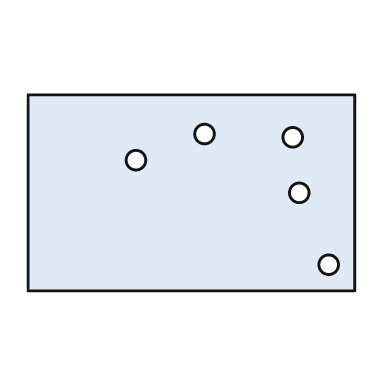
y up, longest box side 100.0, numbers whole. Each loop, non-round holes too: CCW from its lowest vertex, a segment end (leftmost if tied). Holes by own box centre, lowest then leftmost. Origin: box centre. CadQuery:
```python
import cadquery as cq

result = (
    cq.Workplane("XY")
    .moveTo(-50.0, -30.0)
    .lineTo(50.0, -30.0)
    .lineTo(50.0, 30.0)
    .lineTo(-50.0, 30.0)
    .close()
    .moveTo(42.0, -22.0)
    .circle(3.0)
    .moveTo(33.0, 0.0)
    .circle(3.0)
    .moveTo(-17.0, 10.0)
    .circle(3.0)
    .moveTo(31.0, 17.0)
    .circle(3.0)
    .moveTo(4.0, 18.0)
    .circle(3.0)
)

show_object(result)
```